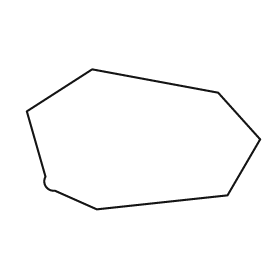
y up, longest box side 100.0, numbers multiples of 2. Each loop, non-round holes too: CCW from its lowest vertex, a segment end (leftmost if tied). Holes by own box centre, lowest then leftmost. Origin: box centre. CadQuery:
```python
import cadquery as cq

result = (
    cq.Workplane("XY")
    .moveTo(-20.0, -30.0)
    .lineTo(36.0, -24.0)
    .lineTo(50.0, 0.0)
    .lineTo(32.0, 20.0)
    .lineTo(-22.0, 30.0)
    .lineTo(-50.0, 12.0)
    .lineTo(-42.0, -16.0)
    .threePointArc((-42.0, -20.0), (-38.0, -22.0))
    .close()
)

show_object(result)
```